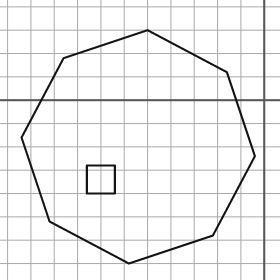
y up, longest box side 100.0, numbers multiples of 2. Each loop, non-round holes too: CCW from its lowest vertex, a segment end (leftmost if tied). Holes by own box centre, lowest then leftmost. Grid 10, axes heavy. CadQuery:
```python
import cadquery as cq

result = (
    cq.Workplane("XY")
    .moveTo(-58.0, -70.0)
    .lineTo(-22.0, -58.0)
    .lineTo(-4.0, -24.0)
    .lineTo(-16.0, 12.0)
    .lineTo(-50.0, 30.0)
    .lineTo(-86.0, 18.0)
    .lineTo(-104.0, -16.0)
    .lineTo(-92.0, -52.0)
    .close()
    .moveTo(-76.0, -40.0)
    .lineTo(-64.0, -40.0)
    .lineTo(-64.0, -28.0)
    .lineTo(-76.0, -28.0)
    .close()
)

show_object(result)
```